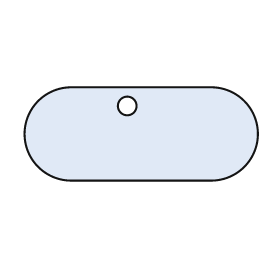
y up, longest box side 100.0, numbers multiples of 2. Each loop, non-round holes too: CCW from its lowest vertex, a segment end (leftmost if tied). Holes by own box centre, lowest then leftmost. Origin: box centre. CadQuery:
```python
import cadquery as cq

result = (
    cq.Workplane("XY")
    .moveTo(-30.0, -20.0)
    .lineTo(30.0, -20.0)
    .threePointArc((50.0, 0.0), (30.0, 20.0))
    .lineTo(-30.0, 20.0)
    .threePointArc((-50.0, 0.0), (-30.0, -20.0))
    .close()
    .moveTo(-6.0, 12.0)
    .circle(4.0)
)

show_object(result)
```